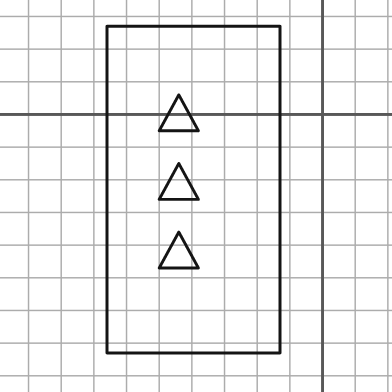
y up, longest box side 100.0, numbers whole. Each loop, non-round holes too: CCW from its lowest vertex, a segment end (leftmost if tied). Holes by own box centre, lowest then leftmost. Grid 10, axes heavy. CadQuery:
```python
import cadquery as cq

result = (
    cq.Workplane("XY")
    .moveTo(-66.0, -73.0)
    .lineTo(-13.0, -73.0)
    .lineTo(-13.0, 27.0)
    .lineTo(-66.0, 27.0)
    .close()
    .moveTo(-50.0, -47.0)
    .lineTo(-38.0, -47.0)
    .lineTo(-44.0, -36.0)
    .close()
    .moveTo(-50.0, -26.0)
    .lineTo(-38.0, -26.0)
    .lineTo(-44.0, -15.0)
    .close()
    .moveTo(-50.0, -5.0)
    .lineTo(-38.0, -5.0)
    .lineTo(-44.0, 6.0)
    .close()
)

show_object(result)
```